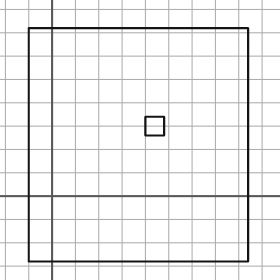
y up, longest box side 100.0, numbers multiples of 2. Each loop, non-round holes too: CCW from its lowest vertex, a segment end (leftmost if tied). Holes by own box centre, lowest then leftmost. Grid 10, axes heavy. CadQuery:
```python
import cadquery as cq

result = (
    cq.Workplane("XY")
    .moveTo(-10.0, -28.0)
    .lineTo(84.0, -28.0)
    .lineTo(84.0, 72.0)
    .lineTo(-10.0, 72.0)
    .close()
    .moveTo(40.0, 26.0)
    .lineTo(48.0, 26.0)
    .lineTo(48.0, 34.0)
    .lineTo(40.0, 34.0)
    .close()
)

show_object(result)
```